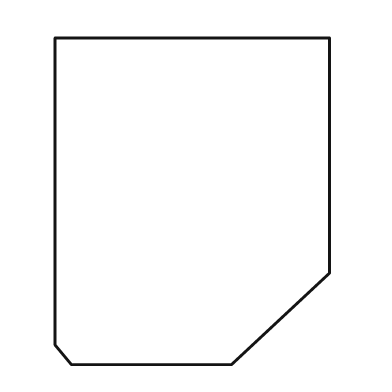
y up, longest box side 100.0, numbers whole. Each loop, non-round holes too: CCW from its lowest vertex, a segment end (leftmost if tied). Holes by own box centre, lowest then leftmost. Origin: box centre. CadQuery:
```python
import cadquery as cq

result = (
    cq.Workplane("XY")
    .moveTo(-37.0, -50.0)
    .lineTo(12.0, -50.0)
    .lineTo(42.0, -22.0)
    .lineTo(42.0, 50.0)
    .lineTo(-42.0, 50.0)
    .lineTo(-42.0, -44.0)
    .close()
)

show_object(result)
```